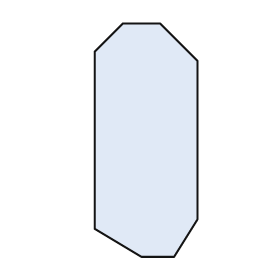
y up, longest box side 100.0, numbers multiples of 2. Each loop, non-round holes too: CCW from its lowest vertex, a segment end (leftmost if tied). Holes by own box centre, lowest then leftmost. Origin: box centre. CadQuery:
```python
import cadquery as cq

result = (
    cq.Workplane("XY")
    .moveTo(-2.0, -50.0)
    .lineTo(12.0, -50.0)
    .lineTo(22.0, -34.0)
    .lineTo(22.0, 34.0)
    .lineTo(6.0, 50.0)
    .lineTo(-10.0, 50.0)
    .lineTo(-22.0, 38.0)
    .lineTo(-22.0, -38.0)
    .close()
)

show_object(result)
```